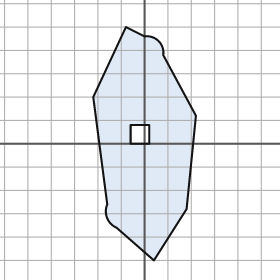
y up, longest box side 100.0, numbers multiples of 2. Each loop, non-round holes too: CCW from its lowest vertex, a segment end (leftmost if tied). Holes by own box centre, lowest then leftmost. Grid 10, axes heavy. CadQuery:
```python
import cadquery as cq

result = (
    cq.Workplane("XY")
    .moveTo(4.0, -50.0)
    .lineTo(18.0, -28.0)
    .lineTo(22.0, 12.0)
    .lineTo(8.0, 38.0)
    .threePointArc((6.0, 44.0), (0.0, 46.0))
    .lineTo(-8.0, 50.0)
    .lineTo(-22.0, 20.0)
    .lineTo(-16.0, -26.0)
    .threePointArc((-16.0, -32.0), (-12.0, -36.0))
    .close()
    .moveTo(-6.0, 0.0)
    .lineTo(2.0, 0.0)
    .lineTo(2.0, 8.0)
    .lineTo(-6.0, 8.0)
    .close()
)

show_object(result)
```